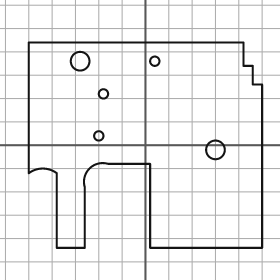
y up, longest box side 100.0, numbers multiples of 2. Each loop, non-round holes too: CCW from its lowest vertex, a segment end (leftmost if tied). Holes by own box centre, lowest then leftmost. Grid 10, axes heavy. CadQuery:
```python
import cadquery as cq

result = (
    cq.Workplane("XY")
    .moveTo(-38.0, -44.0)
    .lineTo(-26.0, -44.0)
    .lineTo(-26.0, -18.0)
    .threePointArc((-24.0, -10.0), (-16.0, -8.0))
    .lineTo(2.0, -8.0)
    .lineTo(2.0, -44.0)
    .lineTo(50.0, -44.0)
    .lineTo(50.0, 26.0)
    .lineTo(46.0, 26.0)
    .lineTo(46.0, 34.0)
    .lineTo(42.0, 34.0)
    .lineTo(42.0, 44.0)
    .lineTo(-50.0, 44.0)
    .lineTo(-50.0, -12.0)
    .threePointArc((-44.0, -10.0), (-38.0, -12.0))
    .close()
    .moveTo(30.0, -2.0)
    .circle(4.0)
    .moveTo(-20.0, 4.0)
    .circle(2.0)
    .moveTo(-18.0, 22.0)
    .circle(2.0)
    .moveTo(-28.0, 36.0)
    .circle(4.0)
    .moveTo(4.0, 36.0)
    .circle(2.0)
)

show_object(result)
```